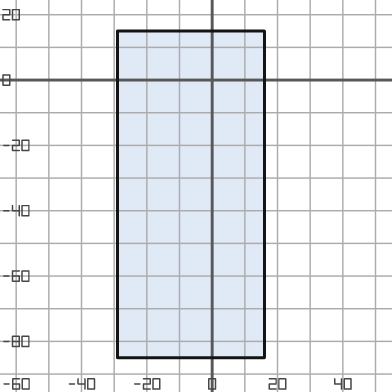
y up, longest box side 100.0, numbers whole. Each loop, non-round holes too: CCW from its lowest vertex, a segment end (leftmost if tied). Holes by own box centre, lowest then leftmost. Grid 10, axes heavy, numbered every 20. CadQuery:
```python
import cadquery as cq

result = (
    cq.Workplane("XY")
    .moveTo(-29.0, -85.0)
    .lineTo(16.0, -85.0)
    .lineTo(16.0, 15.0)
    .lineTo(-29.0, 15.0)
    .close()
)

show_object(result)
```